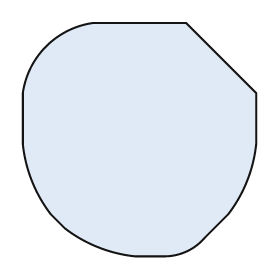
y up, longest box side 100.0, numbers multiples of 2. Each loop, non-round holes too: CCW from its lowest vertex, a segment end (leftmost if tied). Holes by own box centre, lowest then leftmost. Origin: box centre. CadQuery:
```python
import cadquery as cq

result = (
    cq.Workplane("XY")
    .moveTo(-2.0, -50.0)
    .lineTo(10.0, -50.0)
    .threePointArc((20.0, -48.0), (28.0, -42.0))
    .lineTo(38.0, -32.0)
    .threePointArc((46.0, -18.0), (50.0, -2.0))
    .lineTo(50.0, 20.0)
    .lineTo(20.0, 50.0)
    .lineTo(-20.0, 50.0)
    .threePointArc((-40.0, 40.0), (-50.0, 20.0))
    .lineTo(-50.0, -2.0)
    .threePointArc((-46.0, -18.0), (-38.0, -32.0))
    .lineTo(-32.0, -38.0)
    .threePointArc((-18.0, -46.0), (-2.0, -50.0))
    .close()
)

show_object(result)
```